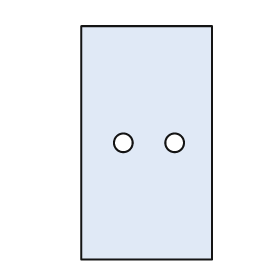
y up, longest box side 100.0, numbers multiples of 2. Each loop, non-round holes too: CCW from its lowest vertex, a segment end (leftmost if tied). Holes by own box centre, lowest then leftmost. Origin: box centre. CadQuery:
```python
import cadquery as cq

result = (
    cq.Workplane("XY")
    .moveTo(-28.0, -50.0)
    .lineTo(28.0, -50.0)
    .lineTo(28.0, 50.0)
    .lineTo(-28.0, 50.0)
    .close()
    .moveTo(-10.0, 0.0)
    .circle(4.0)
    .moveTo(12.0, 0.0)
    .circle(4.0)
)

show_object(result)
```